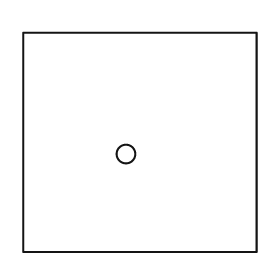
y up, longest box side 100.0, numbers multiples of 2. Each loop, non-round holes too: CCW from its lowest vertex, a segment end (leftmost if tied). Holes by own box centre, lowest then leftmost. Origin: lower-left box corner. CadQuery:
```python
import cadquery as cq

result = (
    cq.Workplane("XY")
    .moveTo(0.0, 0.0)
    .lineTo(100.0, 0.0)
    .lineTo(100.0, 94.0)
    .lineTo(0.0, 94.0)
    .close()
    .moveTo(44.0, 42.0)
    .circle(4.0)
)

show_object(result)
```